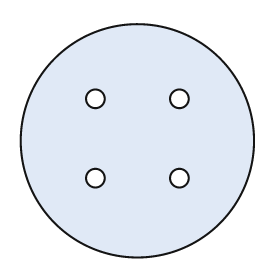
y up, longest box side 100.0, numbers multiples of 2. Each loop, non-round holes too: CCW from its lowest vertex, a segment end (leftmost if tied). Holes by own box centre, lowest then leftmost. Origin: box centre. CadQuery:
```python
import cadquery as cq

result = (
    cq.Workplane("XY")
    .moveTo(0.0, 0.0)
    .circle(50.0)
    .moveTo(-18.0, -16.0)
    .circle(4.0)
    .moveTo(18.0, -16.0)
    .circle(4.0)
    .moveTo(-18.0, 18.0)
    .circle(4.0)
    .moveTo(18.0, 18.0)
    .circle(4.0)
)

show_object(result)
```